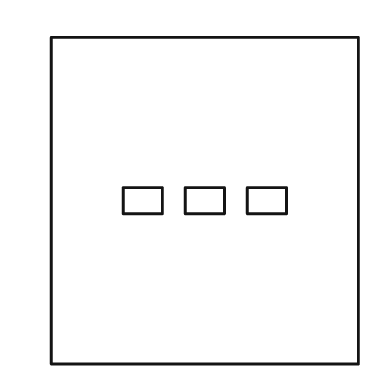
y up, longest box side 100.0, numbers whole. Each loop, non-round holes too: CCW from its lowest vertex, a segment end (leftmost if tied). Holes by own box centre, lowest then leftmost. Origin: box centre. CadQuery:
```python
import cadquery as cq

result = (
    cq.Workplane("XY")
    .moveTo(-47.0, -50.0)
    .lineTo(47.0, -50.0)
    .lineTo(47.0, 50.0)
    .lineTo(-47.0, 50.0)
    .close()
    .moveTo(-25.0, -4.0)
    .lineTo(-13.0, -4.0)
    .lineTo(-13.0, 4.0)
    .lineTo(-25.0, 4.0)
    .close()
    .moveTo(-6.0, -4.0)
    .lineTo(6.0, -4.0)
    .lineTo(6.0, 4.0)
    .lineTo(-6.0, 4.0)
    .close()
    .moveTo(13.0, -4.0)
    .lineTo(25.0, -4.0)
    .lineTo(25.0, 4.0)
    .lineTo(13.0, 4.0)
    .close()
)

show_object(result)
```